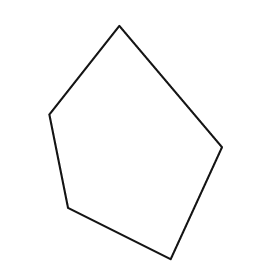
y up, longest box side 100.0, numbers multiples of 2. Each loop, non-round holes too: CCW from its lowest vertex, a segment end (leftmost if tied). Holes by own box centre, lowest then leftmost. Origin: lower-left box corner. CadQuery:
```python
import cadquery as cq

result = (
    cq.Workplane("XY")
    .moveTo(52.0, 0.0)
    .lineTo(74.0, 48.0)
    .lineTo(30.0, 100.0)
    .lineTo(0.0, 62.0)
    .lineTo(8.0, 22.0)
    .close()
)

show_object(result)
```